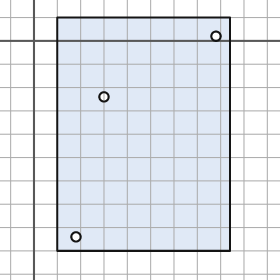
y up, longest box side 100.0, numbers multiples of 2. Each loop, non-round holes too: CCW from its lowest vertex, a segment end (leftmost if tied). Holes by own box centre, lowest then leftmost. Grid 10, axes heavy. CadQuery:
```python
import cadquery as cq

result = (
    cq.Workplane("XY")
    .moveTo(10.0, -90.0)
    .lineTo(84.0, -90.0)
    .lineTo(84.0, 10.0)
    .lineTo(10.0, 10.0)
    .close()
    .moveTo(18.0, -84.0)
    .circle(2.0)
    .moveTo(30.0, -24.0)
    .circle(2.0)
    .moveTo(78.0, 2.0)
    .circle(2.0)
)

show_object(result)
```